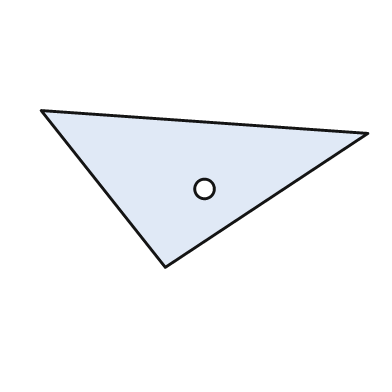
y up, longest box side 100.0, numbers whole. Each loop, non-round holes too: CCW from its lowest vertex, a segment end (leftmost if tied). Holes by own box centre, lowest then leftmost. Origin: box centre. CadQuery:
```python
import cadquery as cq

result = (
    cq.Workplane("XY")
    .moveTo(-12.0, -24.0)
    .lineTo(50.0, 17.0)
    .lineTo(-50.0, 24.0)
    .close()
    .moveTo(0.0, 0.0)
    .circle(3.0)
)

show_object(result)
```